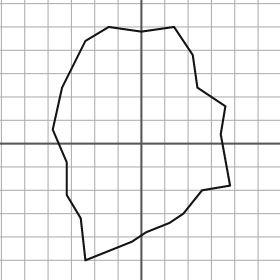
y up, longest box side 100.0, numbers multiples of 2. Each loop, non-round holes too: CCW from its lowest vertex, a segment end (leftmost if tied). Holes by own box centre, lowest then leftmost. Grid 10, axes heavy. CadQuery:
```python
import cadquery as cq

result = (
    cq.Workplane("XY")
    .moveTo(-24.0, -50.0)
    .lineTo(-4.0, -42.0)
    .lineTo(2.0, -38.0)
    .lineTo(12.0, -34.0)
    .lineTo(18.0, -30.0)
    .lineTo(26.0, -20.0)
    .lineTo(38.0, -18.0)
    .lineTo(34.0, 4.0)
    .lineTo(36.0, 16.0)
    .lineTo(24.0, 24.0)
    .lineTo(22.0, 38.0)
    .lineTo(14.0, 50.0)
    .lineTo(0.0, 48.0)
    .lineTo(-14.0, 50.0)
    .lineTo(-24.0, 44.0)
    .lineTo(-34.0, 24.0)
    .lineTo(-38.0, 6.0)
    .lineTo(-32.0, -8.0)
    .lineTo(-32.0, -22.0)
    .lineTo(-26.0, -32.0)
    .close()
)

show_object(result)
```